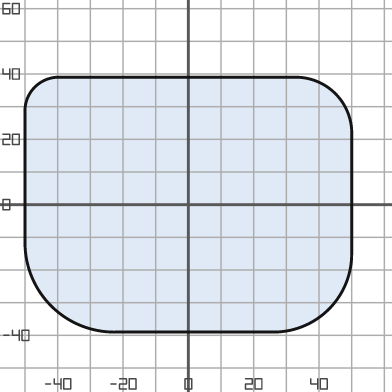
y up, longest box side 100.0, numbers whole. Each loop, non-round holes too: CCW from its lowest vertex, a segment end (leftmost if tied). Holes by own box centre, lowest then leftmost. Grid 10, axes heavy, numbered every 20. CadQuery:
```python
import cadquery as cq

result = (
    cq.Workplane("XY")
    .moveTo(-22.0, -39.0)
    .lineTo(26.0, -39.0)
    .threePointArc((43.0, -32.0), (50.0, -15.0))
    .lineTo(50.0, 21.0)
    .threePointArc((45.0, 34.0), (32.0, 39.0))
    .lineTo(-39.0, 39.0)
    .threePointArc((-47.0, 36.0), (-50.0, 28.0))
    .lineTo(-50.0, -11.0)
    .threePointArc((-42.0, -31.0), (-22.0, -39.0))
    .close()
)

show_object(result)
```